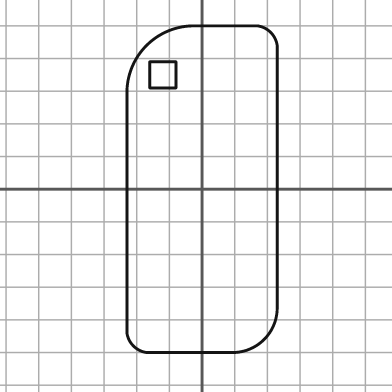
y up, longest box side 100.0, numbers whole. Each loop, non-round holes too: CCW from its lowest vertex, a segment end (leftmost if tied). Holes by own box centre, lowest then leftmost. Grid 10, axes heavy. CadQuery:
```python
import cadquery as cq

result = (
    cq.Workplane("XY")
    .moveTo(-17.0, -50.0)
    .lineTo(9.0, -50.0)
    .threePointArc((19.0, -46.0), (23.0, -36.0))
    .lineTo(23.0, 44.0)
    .threePointArc((21.0, 48.0), (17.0, 50.0))
    .lineTo(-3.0, 50.0)
    .threePointArc((-17.0, 44.0), (-23.0, 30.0))
    .lineTo(-23.0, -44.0)
    .threePointArc((-21.0, -48.0), (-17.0, -50.0))
    .close()
    .moveTo(-16.0, 31.0)
    .lineTo(-8.0, 31.0)
    .lineTo(-8.0, 39.0)
    .lineTo(-16.0, 39.0)
    .close()
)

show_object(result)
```